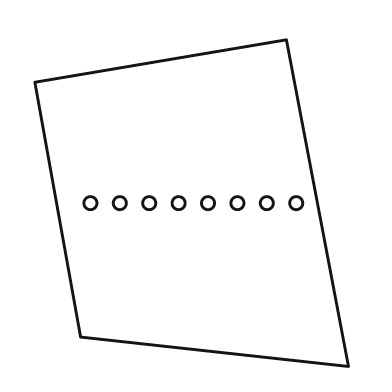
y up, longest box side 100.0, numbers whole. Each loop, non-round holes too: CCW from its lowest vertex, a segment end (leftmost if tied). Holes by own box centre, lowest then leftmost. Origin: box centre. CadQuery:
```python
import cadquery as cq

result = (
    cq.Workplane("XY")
    .moveTo(48.0, -50.0)
    .lineTo(29.0, 50.0)
    .lineTo(-48.0, 37.0)
    .lineTo(-34.0, -41.0)
    .close()
    .moveTo(-31.0, 0.0)
    .circle(2.0)
    .moveTo(-22.0, 0.0)
    .circle(2.0)
    .moveTo(-13.0, 0.0)
    .circle(2.0)
    .moveTo(-4.0, 0.0)
    .circle(2.0)
    .moveTo(5.0, 0.0)
    .circle(2.0)
    .moveTo(14.0, 0.0)
    .circle(2.0)
    .moveTo(23.0, 0.0)
    .circle(2.0)
    .moveTo(32.0, 0.0)
    .circle(2.0)
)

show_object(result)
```